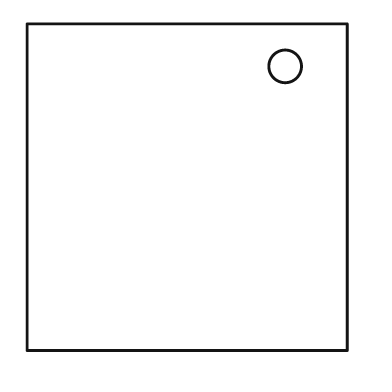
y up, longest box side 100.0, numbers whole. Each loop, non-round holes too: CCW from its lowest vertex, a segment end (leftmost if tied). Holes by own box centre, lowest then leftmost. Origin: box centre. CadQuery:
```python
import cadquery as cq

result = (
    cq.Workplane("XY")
    .moveTo(-49.0, -50.0)
    .lineTo(49.0, -50.0)
    .lineTo(49.0, 50.0)
    .lineTo(-49.0, 50.0)
    .close()
    .moveTo(30.0, 37.0)
    .circle(5.0)
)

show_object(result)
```